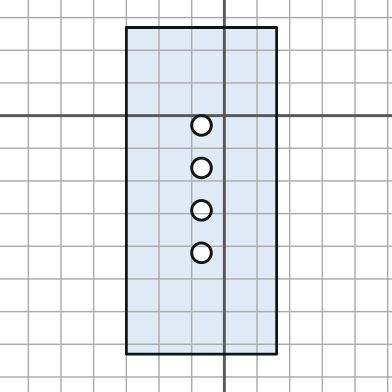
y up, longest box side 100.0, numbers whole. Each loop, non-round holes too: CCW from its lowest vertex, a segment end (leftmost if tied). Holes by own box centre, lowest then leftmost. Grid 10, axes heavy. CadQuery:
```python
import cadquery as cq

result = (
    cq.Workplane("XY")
    .moveTo(-30.0, -73.0)
    .lineTo(16.0, -73.0)
    .lineTo(16.0, 27.0)
    .lineTo(-30.0, 27.0)
    .close()
    .moveTo(-7.0, -42.0)
    .circle(3.0)
    .moveTo(-7.0, -29.0)
    .circle(3.0)
    .moveTo(-7.0, -16.0)
    .circle(3.0)
    .moveTo(-7.0, -3.0)
    .circle(3.0)
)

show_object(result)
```